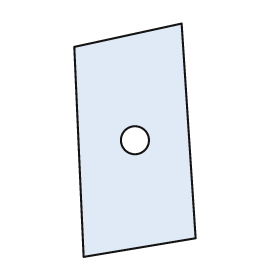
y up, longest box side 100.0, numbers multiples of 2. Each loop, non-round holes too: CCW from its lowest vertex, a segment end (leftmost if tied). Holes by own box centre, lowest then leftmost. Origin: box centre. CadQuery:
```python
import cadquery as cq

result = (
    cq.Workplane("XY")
    .moveTo(-22.0, -50.0)
    .lineTo(26.0, -42.0)
    .lineTo(20.0, 50.0)
    .lineTo(-26.0, 40.0)
    .close()
    .moveTo(0.0, 0.0)
    .circle(6.0)
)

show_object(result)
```